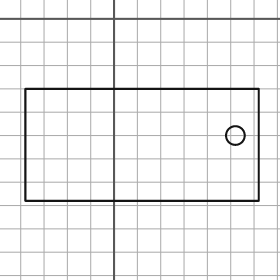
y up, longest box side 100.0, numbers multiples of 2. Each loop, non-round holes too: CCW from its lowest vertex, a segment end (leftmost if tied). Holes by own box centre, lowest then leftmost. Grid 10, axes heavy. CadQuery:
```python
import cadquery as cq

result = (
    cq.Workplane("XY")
    .moveTo(-38.0, -78.0)
    .lineTo(62.0, -78.0)
    .lineTo(62.0, -30.0)
    .lineTo(-38.0, -30.0)
    .close()
    .moveTo(52.0, -50.0)
    .circle(4.0)
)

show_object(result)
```